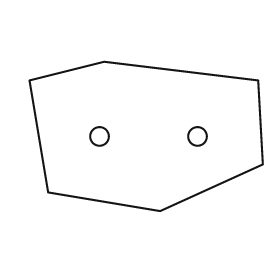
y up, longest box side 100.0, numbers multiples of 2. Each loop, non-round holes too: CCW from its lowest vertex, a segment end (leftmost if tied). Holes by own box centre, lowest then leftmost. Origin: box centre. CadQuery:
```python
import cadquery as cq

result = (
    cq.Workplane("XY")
    .moveTo(6.0, -32.0)
    .lineTo(50.0, -12.0)
    .lineTo(48.0, 24.0)
    .lineTo(-18.0, 32.0)
    .lineTo(-50.0, 24.0)
    .lineTo(-42.0, -24.0)
    .close()
    .moveTo(-20.0, 0.0)
    .circle(4.0)
    .moveTo(22.0, 0.0)
    .circle(4.0)
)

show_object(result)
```